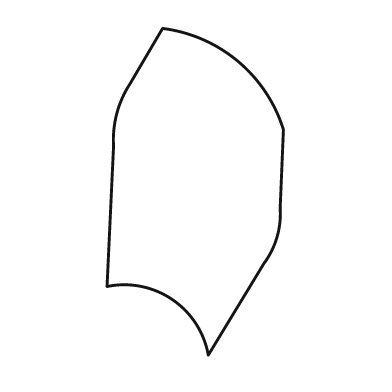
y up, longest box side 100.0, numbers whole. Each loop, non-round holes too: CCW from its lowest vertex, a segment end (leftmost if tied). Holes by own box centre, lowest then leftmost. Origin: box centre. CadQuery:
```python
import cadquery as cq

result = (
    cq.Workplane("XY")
    .moveTo(4.0, -50.0)
    .lineTo(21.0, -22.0)
    .threePointArc((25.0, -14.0), (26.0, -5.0))
    .lineTo(27.0, 19.0)
    .threePointArc((13.0, 40.0), (-10.0, 50.0))
    .lineTo(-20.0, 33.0)
    .threePointArc((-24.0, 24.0), (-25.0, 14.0))
    .lineTo(-27.0, -29.0)
    .threePointArc((-7.0, -33.0), (4.0, -50.0))
    .close()
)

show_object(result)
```